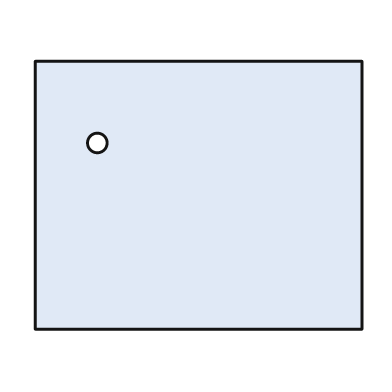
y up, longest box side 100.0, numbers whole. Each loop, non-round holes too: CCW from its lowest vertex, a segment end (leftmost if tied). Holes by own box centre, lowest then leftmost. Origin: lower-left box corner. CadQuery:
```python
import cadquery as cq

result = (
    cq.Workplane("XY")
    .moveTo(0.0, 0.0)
    .lineTo(100.0, 0.0)
    .lineTo(100.0, 82.0)
    .lineTo(0.0, 82.0)
    .close()
    .moveTo(19.0, 57.0)
    .circle(3.0)
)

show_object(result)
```